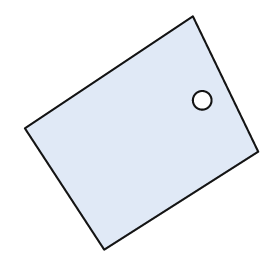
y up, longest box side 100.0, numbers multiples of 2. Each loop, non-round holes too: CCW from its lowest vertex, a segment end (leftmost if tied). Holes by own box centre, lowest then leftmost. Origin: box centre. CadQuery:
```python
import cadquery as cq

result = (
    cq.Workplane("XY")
    .moveTo(-16.0, -50.0)
    .lineTo(50.0, -8.0)
    .lineTo(22.0, 50.0)
    .lineTo(-50.0, 2.0)
    .close()
    .moveTo(26.0, 14.0)
    .circle(4.0)
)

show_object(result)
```